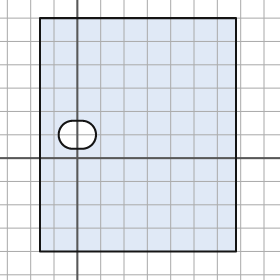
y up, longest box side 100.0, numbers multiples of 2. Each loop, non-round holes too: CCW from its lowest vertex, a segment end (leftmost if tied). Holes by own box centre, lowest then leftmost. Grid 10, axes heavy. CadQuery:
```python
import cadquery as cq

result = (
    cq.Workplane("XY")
    .moveTo(-16.0, -40.0)
    .lineTo(68.0, -40.0)
    .lineTo(68.0, 60.0)
    .lineTo(-16.0, 60.0)
    .close()
    .moveTo(-2.0, 4.0)
    .lineTo(2.0, 4.0)
    .threePointArc((8.0, 10.0), (2.0, 16.0))
    .lineTo(-2.0, 16.0)
    .threePointArc((-8.0, 10.0), (-2.0, 4.0))
    .close()
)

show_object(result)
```